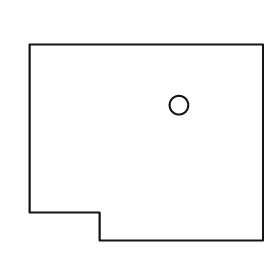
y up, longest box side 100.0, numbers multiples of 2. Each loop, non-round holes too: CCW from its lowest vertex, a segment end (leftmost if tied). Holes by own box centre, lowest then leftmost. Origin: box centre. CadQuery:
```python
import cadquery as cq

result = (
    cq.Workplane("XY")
    .moveTo(-20.0, -42.0)
    .lineTo(50.0, -42.0)
    .lineTo(50.0, 42.0)
    .lineTo(-50.0, 42.0)
    .lineTo(-50.0, -30.0)
    .lineTo(-20.0, -30.0)
    .close()
    .moveTo(14.0, 16.0)
    .circle(4.0)
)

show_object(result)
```